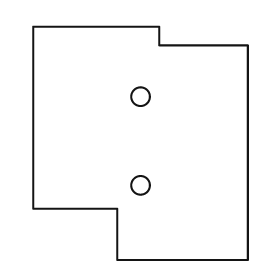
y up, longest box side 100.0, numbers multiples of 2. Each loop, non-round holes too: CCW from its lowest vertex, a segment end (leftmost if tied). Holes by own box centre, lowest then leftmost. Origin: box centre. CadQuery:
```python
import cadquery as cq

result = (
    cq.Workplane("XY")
    .moveTo(-10.0, -50.0)
    .lineTo(46.0, -50.0)
    .lineTo(46.0, 42.0)
    .lineTo(8.0, 42.0)
    .lineTo(8.0, 50.0)
    .lineTo(-46.0, 50.0)
    .lineTo(-46.0, -28.0)
    .lineTo(-10.0, -28.0)
    .close()
    .moveTo(0.0, -18.0)
    .circle(4.0)
    .moveTo(0.0, 20.0)
    .circle(4.0)
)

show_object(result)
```